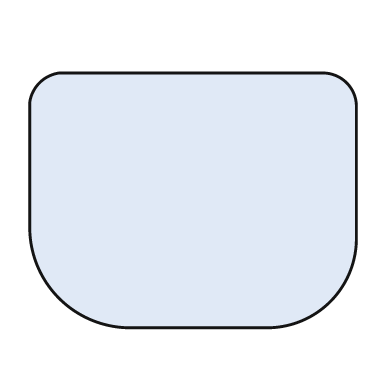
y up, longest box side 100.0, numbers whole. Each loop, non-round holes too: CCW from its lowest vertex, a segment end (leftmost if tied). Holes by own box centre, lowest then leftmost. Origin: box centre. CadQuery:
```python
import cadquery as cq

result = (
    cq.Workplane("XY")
    .moveTo(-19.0, -39.0)
    .lineTo(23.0, -39.0)
    .threePointArc((42.0, -31.0), (50.0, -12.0))
    .lineTo(50.0, 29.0)
    .threePointArc((47.0, 36.0), (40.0, 39.0))
    .lineTo(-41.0, 39.0)
    .threePointArc((-47.0, 36.0), (-50.0, 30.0))
    .lineTo(-50.0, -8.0)
    .threePointArc((-41.0, -30.0), (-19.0, -39.0))
    .close()
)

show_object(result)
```